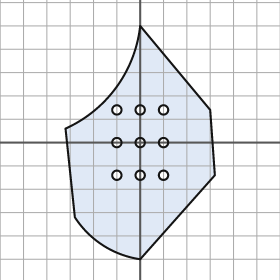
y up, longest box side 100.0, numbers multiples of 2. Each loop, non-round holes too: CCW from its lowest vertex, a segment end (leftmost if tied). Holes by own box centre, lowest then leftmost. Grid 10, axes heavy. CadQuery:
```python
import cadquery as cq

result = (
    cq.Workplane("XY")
    .moveTo(0.0, -50.0)
    .lineTo(32.0, -14.0)
    .lineTo(30.0, 14.0)
    .lineTo(0.0, 50.0)
    .threePointArc((-10.0, 24.0), (-32.0, 6.0))
    .lineTo(-28.0, -32.0)
    .threePointArc((-16.0, -44.0), (0.0, -50.0))
    .close()
    .moveTo(-10.0, -14.0)
    .circle(2.0)
    .moveTo(0.0, -14.0)
    .circle(2.0)
    .moveTo(10.0, -14.0)
    .circle(2.0)
    .moveTo(-10.0, 0.0)
    .circle(2.0)
    .moveTo(0.0, 0.0)
    .circle(2.0)
    .moveTo(10.0, 0.0)
    .circle(2.0)
    .moveTo(-10.0, 14.0)
    .circle(2.0)
    .moveTo(0.0, 14.0)
    .circle(2.0)
    .moveTo(10.0, 14.0)
    .circle(2.0)
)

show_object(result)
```